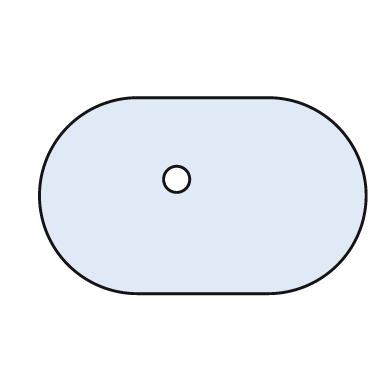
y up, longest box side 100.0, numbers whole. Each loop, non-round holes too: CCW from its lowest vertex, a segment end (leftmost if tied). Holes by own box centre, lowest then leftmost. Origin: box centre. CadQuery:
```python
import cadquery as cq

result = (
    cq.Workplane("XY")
    .moveTo(-20.0, -30.0)
    .lineTo(20.0, -30.0)
    .threePointArc((50.0, 0.0), (20.0, 30.0))
    .lineTo(-20.0, 30.0)
    .threePointArc((-50.0, 0.0), (-20.0, -30.0))
    .close()
    .moveTo(-8.0, 5.0)
    .circle(4.0)
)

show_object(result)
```